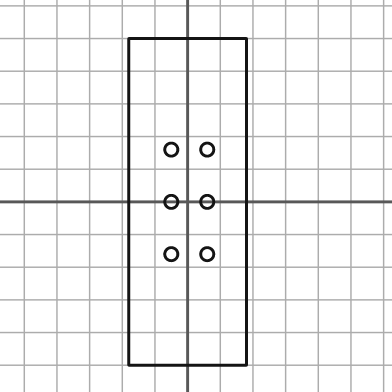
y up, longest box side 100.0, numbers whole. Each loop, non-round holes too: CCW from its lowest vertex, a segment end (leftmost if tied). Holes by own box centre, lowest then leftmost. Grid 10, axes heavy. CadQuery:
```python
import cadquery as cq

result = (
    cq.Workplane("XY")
    .moveTo(-18.0, -50.0)
    .lineTo(18.0, -50.0)
    .lineTo(18.0, 50.0)
    .lineTo(-18.0, 50.0)
    .close()
    .moveTo(-5.0, -16.0)
    .circle(2.0)
    .moveTo(6.0, -16.0)
    .circle(2.0)
    .moveTo(-5.0, 0.0)
    .circle(2.0)
    .moveTo(6.0, 0.0)
    .circle(2.0)
    .moveTo(-5.0, 16.0)
    .circle(2.0)
    .moveTo(6.0, 16.0)
    .circle(2.0)
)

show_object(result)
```